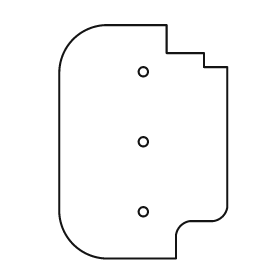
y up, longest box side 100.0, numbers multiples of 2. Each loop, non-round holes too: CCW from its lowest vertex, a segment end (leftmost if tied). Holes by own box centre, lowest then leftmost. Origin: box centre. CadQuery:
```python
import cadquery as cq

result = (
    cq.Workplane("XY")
    .moveTo(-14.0, -50.0)
    .lineTo(14.0, -50.0)
    .lineTo(14.0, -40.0)
    .threePointArc((16.0, -36.0), (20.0, -34.0))
    .lineTo(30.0, -34.0)
    .threePointArc((34.0, -32.0), (36.0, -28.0))
    .lineTo(36.0, 32.0)
    .lineTo(26.0, 32.0)
    .lineTo(26.0, 38.0)
    .lineTo(10.0, 38.0)
    .lineTo(10.0, 50.0)
    .lineTo(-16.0, 50.0)
    .threePointArc((-30.0, 44.0), (-36.0, 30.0))
    .lineTo(-36.0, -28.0)
    .threePointArc((-30.0, -44.0), (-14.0, -50.0))
    .close()
    .moveTo(0.0, -30.0)
    .circle(2.0)
    .moveTo(0.0, 0.0)
    .circle(2.0)
    .moveTo(0.0, 30.0)
    .circle(2.0)
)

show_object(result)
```